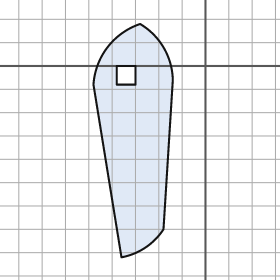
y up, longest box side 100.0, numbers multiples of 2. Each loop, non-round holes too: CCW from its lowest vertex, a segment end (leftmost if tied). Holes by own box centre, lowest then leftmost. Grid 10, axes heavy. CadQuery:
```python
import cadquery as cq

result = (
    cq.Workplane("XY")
    .moveTo(-36.0, -82.0)
    .threePointArc((-26.0, -78.0), (-18.0, -70.0))
    .lineTo(-14.0, -6.0)
    .threePointArc((-18.0, 8.0), (-28.0, 18.0))
    .threePointArc((-42.0, 8.0), (-48.0, -8.0))
    .close()
    .moveTo(-38.0, -8.0)
    .lineTo(-30.0, -8.0)
    .lineTo(-30.0, 0.0)
    .lineTo(-38.0, 0.0)
    .close()
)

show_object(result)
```